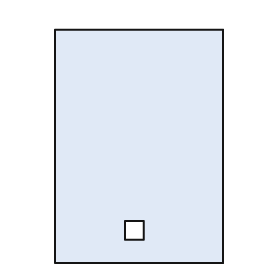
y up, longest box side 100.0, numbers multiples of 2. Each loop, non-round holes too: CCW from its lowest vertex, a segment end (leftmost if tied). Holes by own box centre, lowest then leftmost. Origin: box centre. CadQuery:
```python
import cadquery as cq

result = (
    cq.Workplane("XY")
    .moveTo(-36.0, -50.0)
    .lineTo(36.0, -50.0)
    .lineTo(36.0, 50.0)
    .lineTo(-36.0, 50.0)
    .close()
    .moveTo(-6.0, -40.0)
    .lineTo(2.0, -40.0)
    .lineTo(2.0, -32.0)
    .lineTo(-6.0, -32.0)
    .close()
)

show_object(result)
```